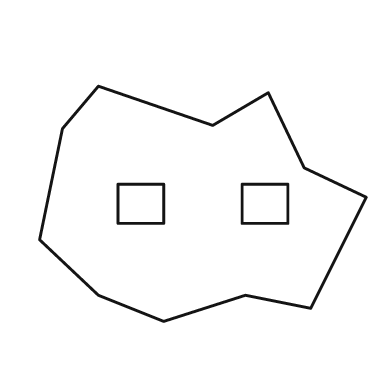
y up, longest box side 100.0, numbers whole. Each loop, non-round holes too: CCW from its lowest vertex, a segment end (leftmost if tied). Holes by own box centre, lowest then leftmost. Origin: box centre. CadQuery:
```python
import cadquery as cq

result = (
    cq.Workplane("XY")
    .moveTo(-12.0, -36.0)
    .lineTo(13.0, -28.0)
    .lineTo(33.0, -32.0)
    .lineTo(50.0, 2.0)
    .lineTo(31.0, 11.0)
    .lineTo(20.0, 34.0)
    .lineTo(3.0, 24.0)
    .lineTo(-32.0, 36.0)
    .lineTo(-43.0, 23.0)
    .lineTo(-50.0, -11.0)
    .lineTo(-32.0, -28.0)
    .close()
    .moveTo(-26.0, -6.0)
    .lineTo(-12.0, -6.0)
    .lineTo(-12.0, 6.0)
    .lineTo(-26.0, 6.0)
    .close()
    .moveTo(12.0, -6.0)
    .lineTo(26.0, -6.0)
    .lineTo(26.0, 6.0)
    .lineTo(12.0, 6.0)
    .close()
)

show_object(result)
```